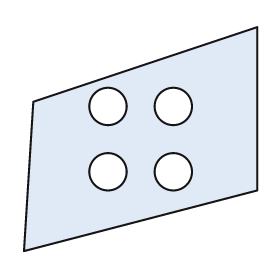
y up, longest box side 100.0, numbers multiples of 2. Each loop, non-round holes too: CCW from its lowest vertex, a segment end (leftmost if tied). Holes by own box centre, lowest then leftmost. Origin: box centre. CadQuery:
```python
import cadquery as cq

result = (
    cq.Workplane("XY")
    .moveTo(-50.0, -48.0)
    .lineTo(50.0, -22.0)
    .lineTo(50.0, 48.0)
    .lineTo(-46.0, 16.0)
    .close()
    .moveTo(-14.0, -14.0)
    .circle(8.0)
    .moveTo(14.0, -14.0)
    .circle(8.0)
    .moveTo(-14.0, 14.0)
    .circle(8.0)
    .moveTo(14.0, 14.0)
    .circle(8.0)
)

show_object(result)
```